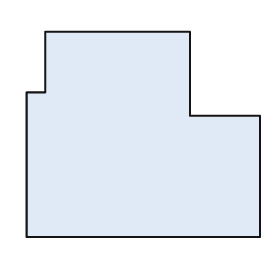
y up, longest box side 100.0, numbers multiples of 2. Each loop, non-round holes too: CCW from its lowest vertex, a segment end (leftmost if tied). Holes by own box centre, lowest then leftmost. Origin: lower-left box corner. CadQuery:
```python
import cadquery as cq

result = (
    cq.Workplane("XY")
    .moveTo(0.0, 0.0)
    .lineTo(100.0, 0.0)
    .lineTo(100.0, 52.0)
    .lineTo(70.0, 52.0)
    .lineTo(70.0, 88.0)
    .lineTo(8.0, 88.0)
    .lineTo(8.0, 62.0)
    .lineTo(0.0, 62.0)
    .close()
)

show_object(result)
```